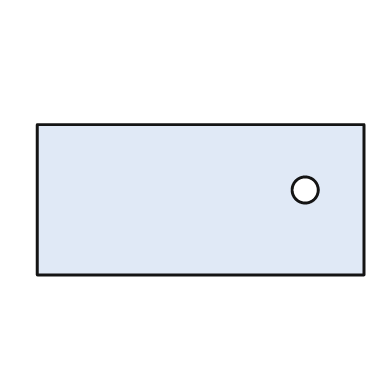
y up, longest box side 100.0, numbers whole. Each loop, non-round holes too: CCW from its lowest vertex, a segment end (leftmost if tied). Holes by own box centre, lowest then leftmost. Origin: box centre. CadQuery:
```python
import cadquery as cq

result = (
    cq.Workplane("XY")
    .moveTo(-50.0, -23.0)
    .lineTo(50.0, -23.0)
    .lineTo(50.0, 23.0)
    .lineTo(-50.0, 23.0)
    .close()
    .moveTo(32.0, 3.0)
    .circle(4.0)
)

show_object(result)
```